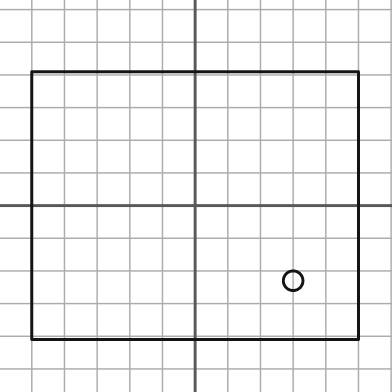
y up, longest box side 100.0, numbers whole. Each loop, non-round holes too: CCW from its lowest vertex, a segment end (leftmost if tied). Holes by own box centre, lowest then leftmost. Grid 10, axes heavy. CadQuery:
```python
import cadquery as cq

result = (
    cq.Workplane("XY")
    .moveTo(-50.0, -41.0)
    .lineTo(50.0, -41.0)
    .lineTo(50.0, 41.0)
    .lineTo(-50.0, 41.0)
    .close()
    .moveTo(30.0, -23.0)
    .circle(3.0)
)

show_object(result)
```